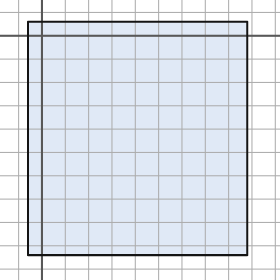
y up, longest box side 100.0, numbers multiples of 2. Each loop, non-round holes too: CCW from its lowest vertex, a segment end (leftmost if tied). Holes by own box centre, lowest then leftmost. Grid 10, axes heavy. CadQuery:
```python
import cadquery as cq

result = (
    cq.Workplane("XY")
    .moveTo(-6.0, -94.0)
    .lineTo(88.0, -94.0)
    .lineTo(88.0, 6.0)
    .lineTo(-6.0, 6.0)
    .close()
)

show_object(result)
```